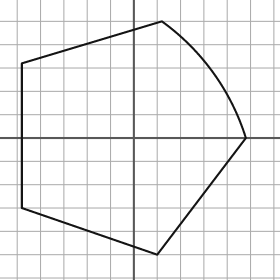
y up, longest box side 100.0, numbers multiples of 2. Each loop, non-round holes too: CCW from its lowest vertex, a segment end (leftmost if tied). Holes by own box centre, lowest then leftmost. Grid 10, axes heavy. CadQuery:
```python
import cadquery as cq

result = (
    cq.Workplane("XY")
    .moveTo(10.0, -50.0)
    .lineTo(48.0, 0.0)
    .threePointArc((34.0, 28.0), (12.0, 50.0))
    .lineTo(-48.0, 32.0)
    .lineTo(-48.0, -30.0)
    .close()
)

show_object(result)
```